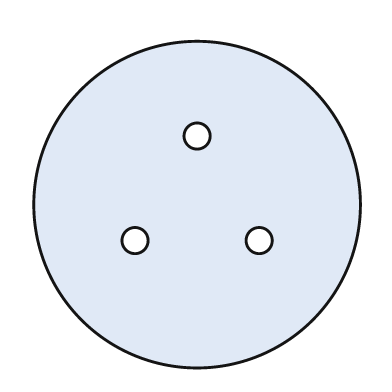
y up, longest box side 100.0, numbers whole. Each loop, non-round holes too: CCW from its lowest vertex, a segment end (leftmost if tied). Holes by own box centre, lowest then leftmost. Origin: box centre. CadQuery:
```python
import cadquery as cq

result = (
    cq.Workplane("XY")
    .moveTo(0.0, 0.0)
    .circle(50.0)
    .moveTo(-19.0, -11.0)
    .circle(4.0)
    .moveTo(19.0, -11.0)
    .circle(4.0)
    .moveTo(0.0, 21.0)
    .circle(4.0)
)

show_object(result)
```